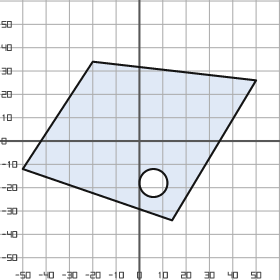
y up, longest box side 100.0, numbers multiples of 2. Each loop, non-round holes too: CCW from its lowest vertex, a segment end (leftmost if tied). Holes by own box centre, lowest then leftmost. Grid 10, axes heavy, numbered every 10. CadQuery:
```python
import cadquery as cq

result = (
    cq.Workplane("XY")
    .moveTo(14.0, -34.0)
    .lineTo(50.0, 26.0)
    .lineTo(-20.0, 34.0)
    .lineTo(-50.0, -12.0)
    .close()
    .moveTo(6.0, -18.0)
    .circle(6.0)
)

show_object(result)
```